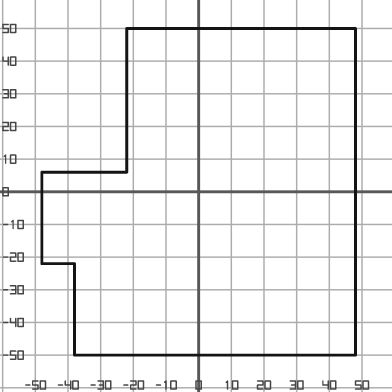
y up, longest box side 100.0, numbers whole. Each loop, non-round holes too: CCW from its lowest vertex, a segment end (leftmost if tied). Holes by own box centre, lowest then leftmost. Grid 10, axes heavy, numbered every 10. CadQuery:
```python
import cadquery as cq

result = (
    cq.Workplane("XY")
    .moveTo(-38.0, -50.0)
    .lineTo(48.0, -50.0)
    .lineTo(48.0, 50.0)
    .lineTo(-22.0, 50.0)
    .lineTo(-22.0, 6.0)
    .lineTo(-48.0, 6.0)
    .lineTo(-48.0, -22.0)
    .lineTo(-38.0, -22.0)
    .close()
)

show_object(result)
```